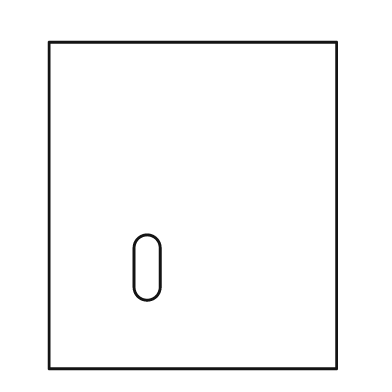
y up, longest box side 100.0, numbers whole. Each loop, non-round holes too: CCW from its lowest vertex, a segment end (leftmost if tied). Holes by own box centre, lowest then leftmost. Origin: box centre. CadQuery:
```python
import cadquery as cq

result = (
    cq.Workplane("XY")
    .moveTo(-44.0, -50.0)
    .lineTo(44.0, -50.0)
    .lineTo(44.0, 50.0)
    .lineTo(-44.0, 50.0)
    .close()
    .moveTo(-18.0, -25.0)
    .threePointArc((-14.0, -29.0), (-10.0, -25.0))
    .lineTo(-10.0, -13.0)
    .threePointArc((-14.0, -9.0), (-18.0, -13.0))
    .close()
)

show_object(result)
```